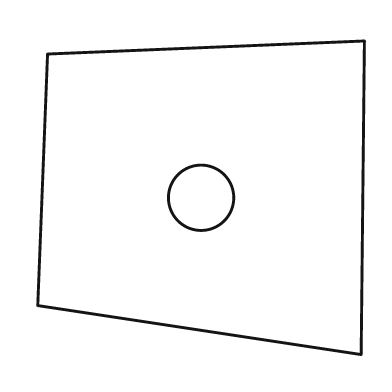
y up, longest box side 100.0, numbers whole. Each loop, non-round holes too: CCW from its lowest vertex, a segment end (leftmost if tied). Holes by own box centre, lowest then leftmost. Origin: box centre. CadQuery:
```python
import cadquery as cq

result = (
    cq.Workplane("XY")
    .moveTo(49.0, -48.0)
    .lineTo(50.0, 48.0)
    .lineTo(-47.0, 44.0)
    .lineTo(-50.0, -33.0)
    .close()
    .moveTo(0.0, 0.0)
    .circle(10.0)
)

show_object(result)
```